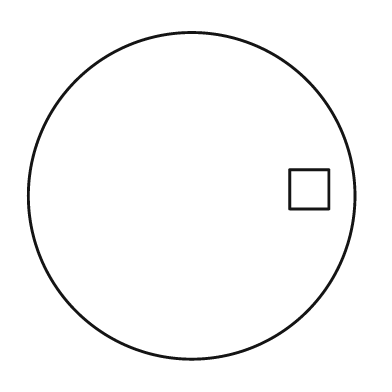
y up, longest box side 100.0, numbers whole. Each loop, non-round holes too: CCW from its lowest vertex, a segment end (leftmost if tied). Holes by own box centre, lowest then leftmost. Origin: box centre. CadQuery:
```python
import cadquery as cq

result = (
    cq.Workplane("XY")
    .moveTo(0.0, 0.0)
    .circle(50.0)
    .moveTo(30.0, -4.0)
    .lineTo(42.0, -4.0)
    .lineTo(42.0, 8.0)
    .lineTo(30.0, 8.0)
    .close()
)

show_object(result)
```